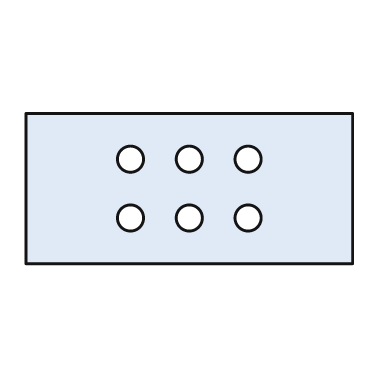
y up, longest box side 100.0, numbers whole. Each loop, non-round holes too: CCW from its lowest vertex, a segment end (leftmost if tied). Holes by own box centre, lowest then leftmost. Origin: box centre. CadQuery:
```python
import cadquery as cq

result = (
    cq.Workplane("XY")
    .moveTo(-50.0, -23.0)
    .lineTo(50.0, -23.0)
    .lineTo(50.0, 23.0)
    .lineTo(-50.0, 23.0)
    .close()
    .moveTo(-18.0, -9.0)
    .circle(4.0)
    .moveTo(0.0, -9.0)
    .circle(4.0)
    .moveTo(18.0, -9.0)
    .circle(4.0)
    .moveTo(-18.0, 9.0)
    .circle(4.0)
    .moveTo(0.0, 9.0)
    .circle(4.0)
    .moveTo(18.0, 9.0)
    .circle(4.0)
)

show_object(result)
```